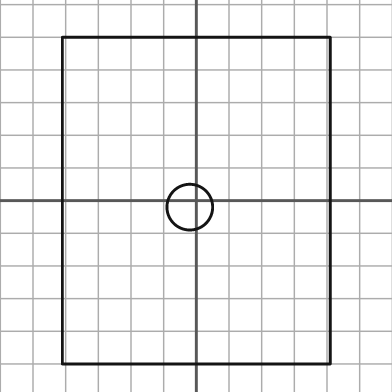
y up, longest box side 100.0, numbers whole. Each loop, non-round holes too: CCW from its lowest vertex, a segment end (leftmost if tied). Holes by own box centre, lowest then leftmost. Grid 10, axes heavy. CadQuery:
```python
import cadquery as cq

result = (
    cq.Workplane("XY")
    .moveTo(-41.0, -50.0)
    .lineTo(41.0, -50.0)
    .lineTo(41.0, 50.0)
    .lineTo(-41.0, 50.0)
    .close()
    .moveTo(-2.0, -2.0)
    .circle(7.0)
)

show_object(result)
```